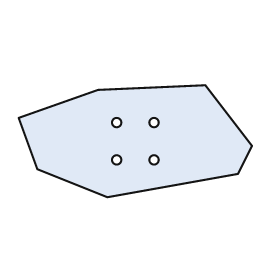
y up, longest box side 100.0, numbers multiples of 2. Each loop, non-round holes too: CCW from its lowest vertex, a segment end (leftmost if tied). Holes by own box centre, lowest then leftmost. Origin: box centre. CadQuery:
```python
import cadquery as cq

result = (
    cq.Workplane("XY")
    .moveTo(-12.0, -24.0)
    .lineTo(44.0, -14.0)
    .lineTo(50.0, -2.0)
    .lineTo(30.0, 24.0)
    .lineTo(-16.0, 22.0)
    .lineTo(-50.0, 10.0)
    .lineTo(-42.0, -12.0)
    .close()
    .moveTo(-8.0, -8.0)
    .circle(2.0)
    .moveTo(8.0, -8.0)
    .circle(2.0)
    .moveTo(-8.0, 8.0)
    .circle(2.0)
    .moveTo(8.0, 8.0)
    .circle(2.0)
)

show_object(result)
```